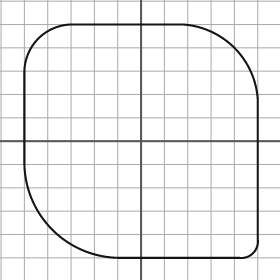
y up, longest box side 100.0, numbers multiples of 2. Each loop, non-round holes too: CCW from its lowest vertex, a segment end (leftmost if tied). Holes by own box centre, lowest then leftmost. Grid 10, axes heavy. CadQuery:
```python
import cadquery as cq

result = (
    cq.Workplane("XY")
    .moveTo(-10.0, -50.0)
    .lineTo(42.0, -50.0)
    .threePointArc((48.0, -48.0), (50.0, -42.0))
    .lineTo(50.0, 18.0)
    .threePointArc((40.0, 40.0), (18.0, 50.0))
    .lineTo(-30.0, 50.0)
    .threePointArc((-44.0, 44.0), (-50.0, 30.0))
    .lineTo(-50.0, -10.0)
    .threePointArc((-38.0, -38.0), (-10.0, -50.0))
    .close()
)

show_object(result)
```